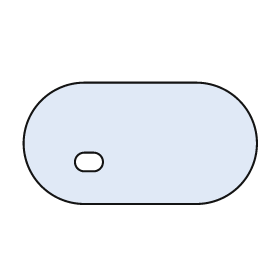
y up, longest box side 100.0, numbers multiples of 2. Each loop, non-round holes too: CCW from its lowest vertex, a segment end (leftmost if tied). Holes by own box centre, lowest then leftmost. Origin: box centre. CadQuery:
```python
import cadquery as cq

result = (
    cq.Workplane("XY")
    .moveTo(-24.0, -26.0)
    .lineTo(24.0, -26.0)
    .threePointArc((50.0, 0.0), (24.0, 26.0))
    .lineTo(-24.0, 26.0)
    .threePointArc((-50.0, 0.0), (-24.0, -26.0))
    .close()
    .moveTo(-24.0, -12.0)
    .lineTo(-20.0, -12.0)
    .threePointArc((-16.0, -8.0), (-20.0, -4.0))
    .lineTo(-24.0, -4.0)
    .threePointArc((-28.0, -8.0), (-24.0, -12.0))
    .close()
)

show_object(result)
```